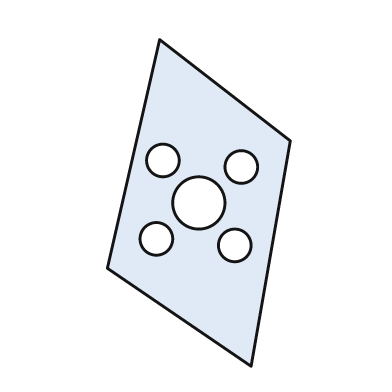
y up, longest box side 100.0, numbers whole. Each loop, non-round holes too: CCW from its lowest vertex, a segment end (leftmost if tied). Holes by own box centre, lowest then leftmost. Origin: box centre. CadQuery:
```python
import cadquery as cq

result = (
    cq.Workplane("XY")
    .moveTo(16.0, -50.0)
    .lineTo(28.0, 19.0)
    .lineTo(-12.0, 50.0)
    .lineTo(-28.0, -20.0)
    .close()
    .moveTo(11.0, -13.0)
    .circle(5.0)
    .moveTo(-13.0, -11.0)
    .circle(5.0)
    .moveTo(0.0, 0.0)
    .circle(8.0)
    .moveTo(13.0, 11.0)
    .circle(5.0)
    .moveTo(-11.0, 13.0)
    .circle(5.0)
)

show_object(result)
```